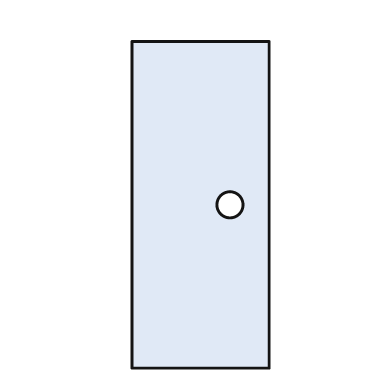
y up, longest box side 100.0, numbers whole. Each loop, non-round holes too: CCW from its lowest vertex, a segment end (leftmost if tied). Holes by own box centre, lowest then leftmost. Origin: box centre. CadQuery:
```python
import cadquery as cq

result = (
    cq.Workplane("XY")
    .moveTo(-21.0, -50.0)
    .lineTo(21.0, -50.0)
    .lineTo(21.0, 50.0)
    .lineTo(-21.0, 50.0)
    .close()
    .moveTo(9.0, 0.0)
    .circle(4.0)
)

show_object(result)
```